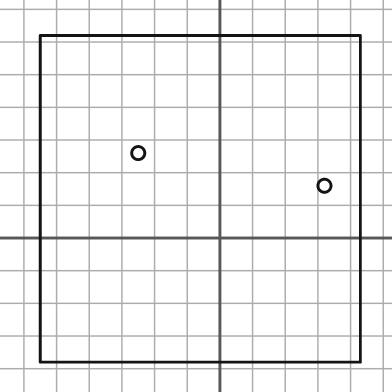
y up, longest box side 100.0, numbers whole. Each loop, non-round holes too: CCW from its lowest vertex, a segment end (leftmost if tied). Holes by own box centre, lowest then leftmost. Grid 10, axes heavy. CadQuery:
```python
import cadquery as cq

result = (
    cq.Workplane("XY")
    .moveTo(-55.0, -38.0)
    .lineTo(43.0, -38.0)
    .lineTo(43.0, 62.0)
    .lineTo(-55.0, 62.0)
    .close()
    .moveTo(32.0, 16.0)
    .circle(2.0)
    .moveTo(-25.0, 26.0)
    .circle(2.0)
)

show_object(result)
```